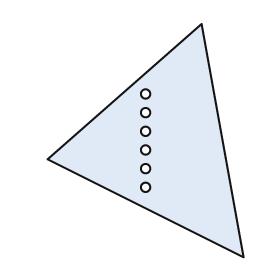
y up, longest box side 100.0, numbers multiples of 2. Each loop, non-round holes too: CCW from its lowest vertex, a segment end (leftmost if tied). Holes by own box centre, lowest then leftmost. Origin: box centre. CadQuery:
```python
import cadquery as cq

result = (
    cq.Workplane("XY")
    .moveTo(42.0, -50.0)
    .lineTo(24.0, 50.0)
    .lineTo(-42.0, -8.0)
    .close()
    .moveTo(0.0, -20.0)
    .circle(2.0)
    .moveTo(0.0, -12.0)
    .circle(2.0)
    .moveTo(0.0, -4.0)
    .circle(2.0)
    .moveTo(0.0, 4.0)
    .circle(2.0)
    .moveTo(0.0, 12.0)
    .circle(2.0)
    .moveTo(0.0, 20.0)
    .circle(2.0)
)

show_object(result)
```